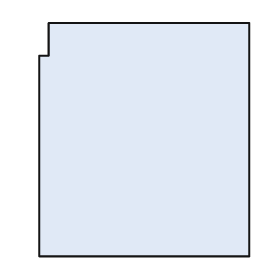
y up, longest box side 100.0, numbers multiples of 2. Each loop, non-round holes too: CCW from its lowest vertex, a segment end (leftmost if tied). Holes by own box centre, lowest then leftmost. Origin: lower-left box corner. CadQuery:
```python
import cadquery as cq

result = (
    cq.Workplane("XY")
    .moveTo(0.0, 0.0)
    .lineTo(90.0, 0.0)
    .lineTo(90.0, 100.0)
    .lineTo(4.0, 100.0)
    .lineTo(4.0, 86.0)
    .lineTo(0.0, 86.0)
    .close()
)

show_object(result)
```